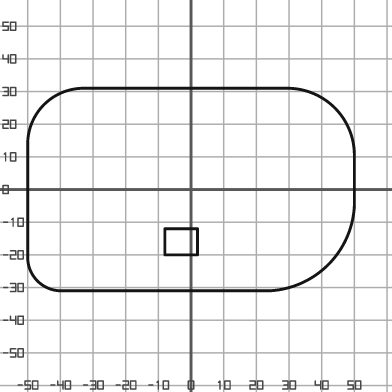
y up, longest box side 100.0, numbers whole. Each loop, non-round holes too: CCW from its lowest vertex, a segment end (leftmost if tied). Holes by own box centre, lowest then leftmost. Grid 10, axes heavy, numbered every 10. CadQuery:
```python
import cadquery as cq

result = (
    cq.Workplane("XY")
    .moveTo(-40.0, -31.0)
    .lineTo(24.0, -31.0)
    .threePointArc((42.0, -23.0), (50.0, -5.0))
    .lineTo(50.0, 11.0)
    .threePointArc((44.0, 25.0), (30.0, 31.0))
    .lineTo(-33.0, 31.0)
    .threePointArc((-45.0, 26.0), (-50.0, 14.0))
    .lineTo(-50.0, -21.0)
    .threePointArc((-47.0, -28.0), (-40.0, -31.0))
    .close()
    .moveTo(-8.0, -20.0)
    .lineTo(2.0, -20.0)
    .lineTo(2.0, -12.0)
    .lineTo(-8.0, -12.0)
    .close()
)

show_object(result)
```